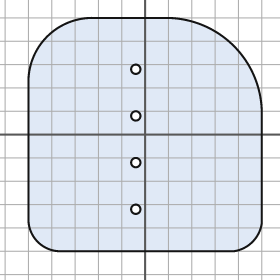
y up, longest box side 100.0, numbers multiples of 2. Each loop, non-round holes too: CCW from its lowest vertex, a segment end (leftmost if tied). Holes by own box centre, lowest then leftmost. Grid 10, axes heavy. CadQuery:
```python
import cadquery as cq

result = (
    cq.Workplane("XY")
    .moveTo(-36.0, -50.0)
    .lineTo(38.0, -50.0)
    .threePointArc((46.0, -46.0), (50.0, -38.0))
    .lineTo(50.0, 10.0)
    .threePointArc((38.0, 38.0), (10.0, 50.0))
    .lineTo(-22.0, 50.0)
    .threePointArc((-42.0, 42.0), (-50.0, 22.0))
    .lineTo(-50.0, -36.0)
    .threePointArc((-46.0, -46.0), (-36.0, -50.0))
    .close()
    .moveTo(-4.0, -32.0)
    .circle(2.0)
    .moveTo(-4.0, -12.0)
    .circle(2.0)
    .moveTo(-4.0, 8.0)
    .circle(2.0)
    .moveTo(-4.0, 28.0)
    .circle(2.0)
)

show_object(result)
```